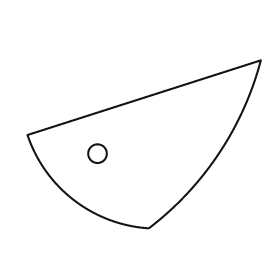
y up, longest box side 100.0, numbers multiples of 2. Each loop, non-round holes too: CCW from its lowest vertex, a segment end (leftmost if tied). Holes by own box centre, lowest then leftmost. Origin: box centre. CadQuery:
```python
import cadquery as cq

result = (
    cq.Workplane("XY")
    .moveTo(2.0, -36.0)
    .threePointArc((32.0, -4.0), (50.0, 36.0))
    .lineTo(-50.0, 4.0)
    .threePointArc((-30.0, -24.0), (2.0, -36.0))
    .close()
    .moveTo(-20.0, -4.0)
    .circle(4.0)
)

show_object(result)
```